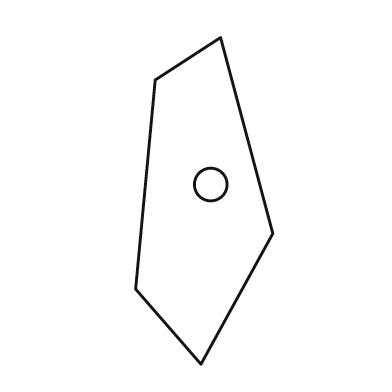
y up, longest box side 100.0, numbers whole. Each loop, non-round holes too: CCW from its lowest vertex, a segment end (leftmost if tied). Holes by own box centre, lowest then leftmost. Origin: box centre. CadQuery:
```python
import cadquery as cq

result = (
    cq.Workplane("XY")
    .moveTo(-1.0, -50.0)
    .lineTo(21.0, -10.0)
    .lineTo(5.0, 50.0)
    .lineTo(-15.0, 37.0)
    .lineTo(-21.0, -27.0)
    .close()
    .moveTo(2.0, 5.0)
    .circle(5.0)
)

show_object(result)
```